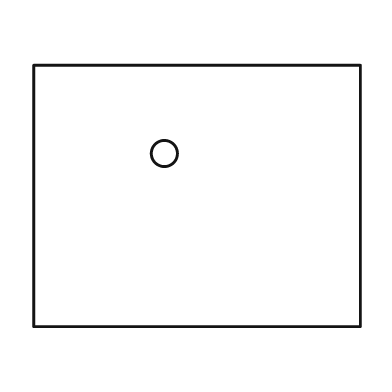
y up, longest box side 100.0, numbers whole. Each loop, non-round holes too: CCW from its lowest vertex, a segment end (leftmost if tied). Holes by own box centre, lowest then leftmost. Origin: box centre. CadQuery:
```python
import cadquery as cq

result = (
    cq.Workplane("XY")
    .moveTo(-50.0, -40.0)
    .lineTo(50.0, -40.0)
    .lineTo(50.0, 40.0)
    .lineTo(-50.0, 40.0)
    .close()
    .moveTo(-10.0, 13.0)
    .circle(4.0)
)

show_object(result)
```